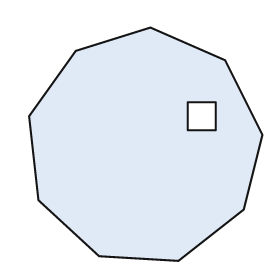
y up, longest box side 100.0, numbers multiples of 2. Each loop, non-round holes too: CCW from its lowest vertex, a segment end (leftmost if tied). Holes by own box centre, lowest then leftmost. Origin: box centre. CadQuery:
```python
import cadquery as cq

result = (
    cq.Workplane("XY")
    .moveTo(14.0, -50.0)
    .lineTo(42.0, -28.0)
    .lineTo(50.0, 4.0)
    .lineTo(34.0, 36.0)
    .lineTo(2.0, 50.0)
    .lineTo(-30.0, 40.0)
    .lineTo(-50.0, 12.0)
    .lineTo(-46.0, -24.0)
    .lineTo(-20.0, -48.0)
    .close()
    .moveTo(18.0, 6.0)
    .lineTo(30.0, 6.0)
    .lineTo(30.0, 18.0)
    .lineTo(18.0, 18.0)
    .close()
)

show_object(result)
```